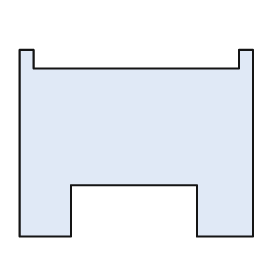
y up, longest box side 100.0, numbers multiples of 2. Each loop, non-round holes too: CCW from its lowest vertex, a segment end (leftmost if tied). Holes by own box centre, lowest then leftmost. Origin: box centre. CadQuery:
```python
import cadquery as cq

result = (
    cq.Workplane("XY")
    .moveTo(-50.0, -40.0)
    .lineTo(-28.0, -40.0)
    .lineTo(-28.0, -18.0)
    .lineTo(26.0, -18.0)
    .lineTo(26.0, -40.0)
    .lineTo(50.0, -40.0)
    .lineTo(50.0, 40.0)
    .lineTo(44.0, 40.0)
    .lineTo(44.0, 32.0)
    .lineTo(-44.0, 32.0)
    .lineTo(-44.0, 40.0)
    .lineTo(-50.0, 40.0)
    .close()
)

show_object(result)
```